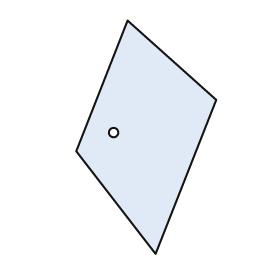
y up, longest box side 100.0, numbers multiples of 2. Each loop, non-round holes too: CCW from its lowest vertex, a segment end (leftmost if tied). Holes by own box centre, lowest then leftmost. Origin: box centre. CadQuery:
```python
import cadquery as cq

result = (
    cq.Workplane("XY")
    .moveTo(4.0, -50.0)
    .lineTo(30.0, 16.0)
    .lineTo(-8.0, 50.0)
    .lineTo(-30.0, -6.0)
    .close()
    .moveTo(-14.0, 2.0)
    .circle(2.0)
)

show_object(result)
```